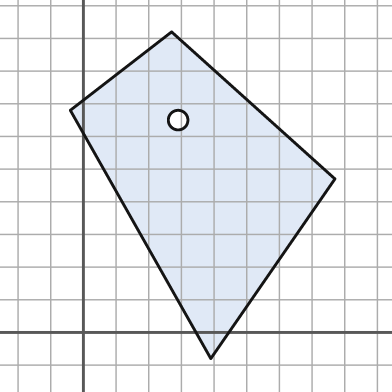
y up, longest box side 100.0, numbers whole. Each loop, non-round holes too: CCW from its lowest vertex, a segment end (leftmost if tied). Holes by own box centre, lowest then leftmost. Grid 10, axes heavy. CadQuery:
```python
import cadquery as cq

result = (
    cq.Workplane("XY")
    .moveTo(39.0, -8.0)
    .lineTo(77.0, 47.0)
    .lineTo(27.0, 92.0)
    .lineTo(-4.0, 68.0)
    .close()
    .moveTo(29.0, 65.0)
    .circle(3.0)
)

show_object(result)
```